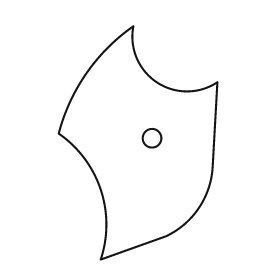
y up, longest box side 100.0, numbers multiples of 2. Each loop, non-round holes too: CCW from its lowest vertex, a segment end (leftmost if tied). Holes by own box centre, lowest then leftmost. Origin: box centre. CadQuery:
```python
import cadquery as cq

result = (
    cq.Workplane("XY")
    .moveTo(-16.0, -50.0)
    .lineTo(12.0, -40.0)
    .threePointArc((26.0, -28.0), (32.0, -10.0))
    .lineTo(34.0, 26.0)
    .threePointArc((8.0, 26.0), (-2.0, 50.0))
    .threePointArc((-22.0, 30.0), (-34.0, 4.0))
    .threePointArc((-16.0, -20.0), (-16.0, -50.0))
    .close()
    .moveTo(6.0, 2.0)
    .circle(4.0)
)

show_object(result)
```